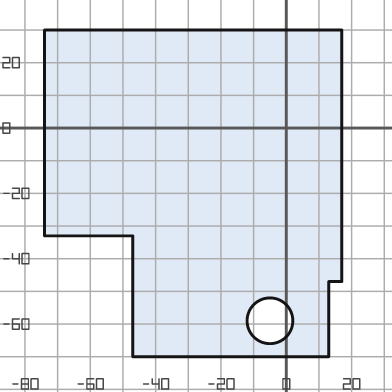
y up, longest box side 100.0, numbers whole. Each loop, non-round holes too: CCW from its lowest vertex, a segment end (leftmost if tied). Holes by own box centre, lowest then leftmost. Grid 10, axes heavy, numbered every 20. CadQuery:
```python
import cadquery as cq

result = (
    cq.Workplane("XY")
    .moveTo(-47.0, -70.0)
    .lineTo(13.0, -70.0)
    .lineTo(13.0, -47.0)
    .lineTo(17.0, -47.0)
    .lineTo(17.0, 30.0)
    .lineTo(-74.0, 30.0)
    .lineTo(-74.0, -33.0)
    .lineTo(-47.0, -33.0)
    .close()
    .moveTo(-5.0, -59.0)
    .circle(7.0)
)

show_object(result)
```